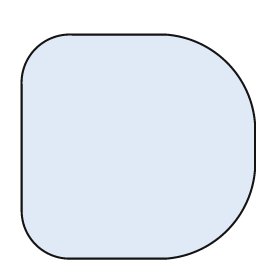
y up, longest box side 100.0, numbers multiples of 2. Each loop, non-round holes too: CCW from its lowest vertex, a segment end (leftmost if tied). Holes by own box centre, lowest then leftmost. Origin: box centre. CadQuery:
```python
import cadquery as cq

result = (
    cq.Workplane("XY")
    .moveTo(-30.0, -48.0)
    .lineTo(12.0, -48.0)
    .threePointArc((38.0, -36.0), (50.0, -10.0))
    .lineTo(50.0, 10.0)
    .threePointArc((38.0, 36.0), (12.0, 48.0))
    .lineTo(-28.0, 48.0)
    .threePointArc((-44.0, 42.0), (-50.0, 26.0))
    .lineTo(-50.0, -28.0)
    .threePointArc((-44.0, -42.0), (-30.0, -48.0))
    .close()
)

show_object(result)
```